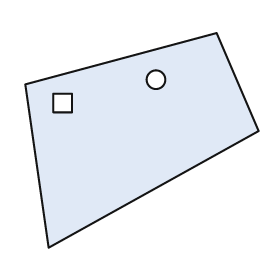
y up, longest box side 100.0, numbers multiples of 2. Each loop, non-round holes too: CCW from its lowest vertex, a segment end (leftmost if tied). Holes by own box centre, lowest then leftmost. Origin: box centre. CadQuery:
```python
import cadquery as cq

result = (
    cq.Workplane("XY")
    .moveTo(-40.0, -46.0)
    .lineTo(50.0, 4.0)
    .lineTo(32.0, 46.0)
    .lineTo(-50.0, 24.0)
    .close()
    .moveTo(-38.0, 12.0)
    .lineTo(-30.0, 12.0)
    .lineTo(-30.0, 20.0)
    .lineTo(-38.0, 20.0)
    .close()
    .moveTo(6.0, 26.0)
    .circle(4.0)
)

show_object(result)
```